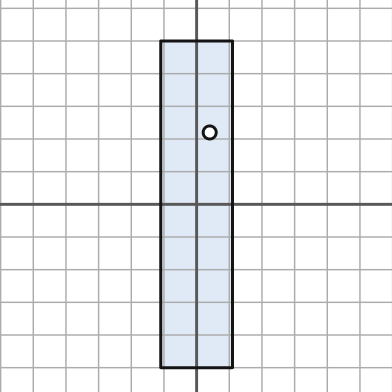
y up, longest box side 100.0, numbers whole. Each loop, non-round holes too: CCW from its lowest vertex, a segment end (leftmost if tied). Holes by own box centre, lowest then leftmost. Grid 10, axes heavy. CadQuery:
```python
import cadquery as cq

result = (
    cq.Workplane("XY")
    .moveTo(-11.0, -50.0)
    .lineTo(11.0, -50.0)
    .lineTo(11.0, 50.0)
    .lineTo(-11.0, 50.0)
    .close()
    .moveTo(4.0, 22.0)
    .circle(2.0)
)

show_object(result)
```